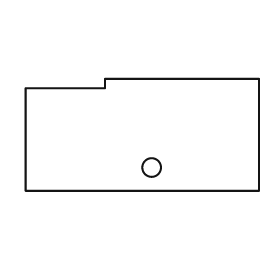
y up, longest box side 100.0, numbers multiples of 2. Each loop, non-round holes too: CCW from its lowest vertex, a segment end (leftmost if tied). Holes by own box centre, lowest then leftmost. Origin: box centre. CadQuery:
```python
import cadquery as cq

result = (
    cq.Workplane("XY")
    .moveTo(-50.0, -24.0)
    .lineTo(50.0, -24.0)
    .lineTo(50.0, 24.0)
    .lineTo(-16.0, 24.0)
    .lineTo(-16.0, 20.0)
    .lineTo(-50.0, 20.0)
    .close()
    .moveTo(4.0, -14.0)
    .circle(4.0)
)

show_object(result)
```